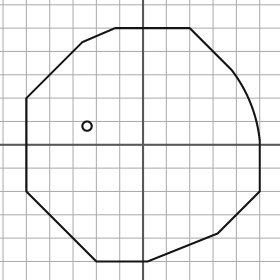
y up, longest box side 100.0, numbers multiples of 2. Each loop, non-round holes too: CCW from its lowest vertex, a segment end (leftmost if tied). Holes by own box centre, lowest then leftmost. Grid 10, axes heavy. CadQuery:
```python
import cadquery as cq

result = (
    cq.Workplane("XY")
    .moveTo(-20.0, -50.0)
    .lineTo(2.0, -50.0)
    .lineTo(32.0, -38.0)
    .lineTo(50.0, -20.0)
    .lineTo(50.0, 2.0)
    .threePointArc((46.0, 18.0), (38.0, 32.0))
    .lineTo(20.0, 50.0)
    .lineTo(-12.0, 50.0)
    .lineTo(-26.0, 44.0)
    .lineTo(-50.0, 20.0)
    .lineTo(-50.0, -20.0)
    .close()
    .moveTo(-24.0, 8.0)
    .circle(2.0)
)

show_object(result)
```